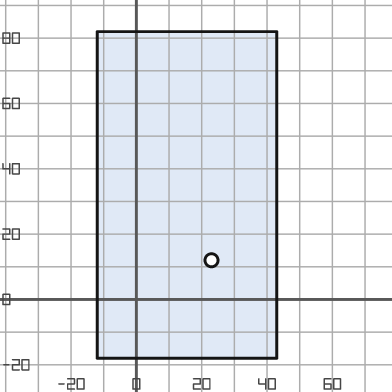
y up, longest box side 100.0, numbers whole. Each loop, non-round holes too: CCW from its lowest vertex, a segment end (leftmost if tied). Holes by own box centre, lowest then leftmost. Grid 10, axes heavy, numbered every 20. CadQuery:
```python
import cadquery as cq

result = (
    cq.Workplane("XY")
    .moveTo(-12.0, -18.0)
    .lineTo(43.0, -18.0)
    .lineTo(43.0, 82.0)
    .lineTo(-12.0, 82.0)
    .close()
    .moveTo(23.0, 12.0)
    .circle(2.0)
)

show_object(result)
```